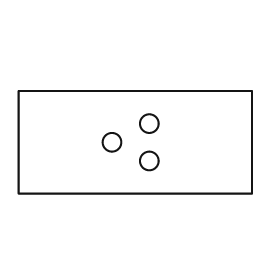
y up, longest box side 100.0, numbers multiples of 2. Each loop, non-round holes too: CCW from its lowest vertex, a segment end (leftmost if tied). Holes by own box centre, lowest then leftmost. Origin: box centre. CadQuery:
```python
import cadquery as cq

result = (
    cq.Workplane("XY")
    .moveTo(-50.0, -22.0)
    .lineTo(50.0, -22.0)
    .lineTo(50.0, 22.0)
    .lineTo(-50.0, 22.0)
    .close()
    .moveTo(6.0, -8.0)
    .circle(4.0)
    .moveTo(-10.0, 0.0)
    .circle(4.0)
    .moveTo(6.0, 8.0)
    .circle(4.0)
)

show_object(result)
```